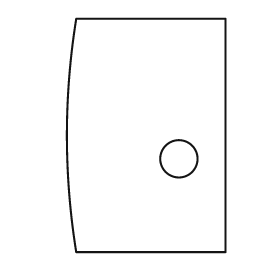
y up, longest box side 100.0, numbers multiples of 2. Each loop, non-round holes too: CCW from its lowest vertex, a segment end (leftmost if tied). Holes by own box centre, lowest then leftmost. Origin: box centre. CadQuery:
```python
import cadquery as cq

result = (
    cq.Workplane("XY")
    .moveTo(-30.0, -50.0)
    .lineTo(34.0, -50.0)
    .lineTo(34.0, 50.0)
    .lineTo(-30.0, 50.0)
    .threePointArc((-34.0, 0.0), (-30.0, -50.0))
    .close()
    .moveTo(14.0, -10.0)
    .circle(8.0)
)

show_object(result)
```